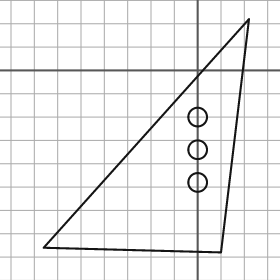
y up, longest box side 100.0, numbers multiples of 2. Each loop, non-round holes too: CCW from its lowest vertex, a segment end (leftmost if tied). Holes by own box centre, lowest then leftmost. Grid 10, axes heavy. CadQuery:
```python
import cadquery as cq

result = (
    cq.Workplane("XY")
    .moveTo(10.0, -78.0)
    .lineTo(22.0, 22.0)
    .lineTo(-66.0, -76.0)
    .close()
    .moveTo(0.0, -48.0)
    .circle(4.0)
    .moveTo(0.0, -34.0)
    .circle(4.0)
    .moveTo(0.0, -20.0)
    .circle(4.0)
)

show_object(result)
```